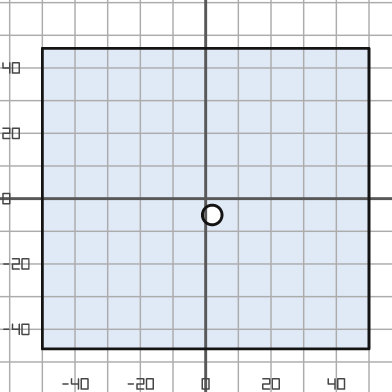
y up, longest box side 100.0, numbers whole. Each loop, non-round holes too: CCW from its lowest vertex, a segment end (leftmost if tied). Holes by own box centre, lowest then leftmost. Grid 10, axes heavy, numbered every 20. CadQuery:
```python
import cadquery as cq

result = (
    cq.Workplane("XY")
    .moveTo(-50.0, -46.0)
    .lineTo(50.0, -46.0)
    .lineTo(50.0, 46.0)
    .lineTo(-50.0, 46.0)
    .close()
    .moveTo(2.0, -5.0)
    .circle(3.0)
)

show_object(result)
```